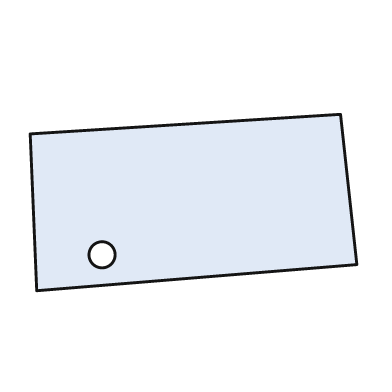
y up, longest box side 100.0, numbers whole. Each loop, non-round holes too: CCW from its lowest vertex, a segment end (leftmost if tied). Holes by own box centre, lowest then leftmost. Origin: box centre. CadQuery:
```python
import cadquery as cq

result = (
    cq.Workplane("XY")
    .moveTo(-48.0, -27.0)
    .lineTo(50.0, -19.0)
    .lineTo(45.0, 27.0)
    .lineTo(-50.0, 21.0)
    .close()
    .moveTo(-28.0, -16.0)
    .circle(4.0)
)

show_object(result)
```